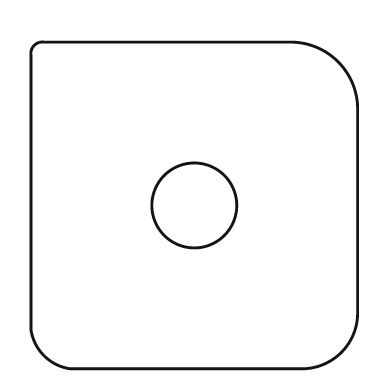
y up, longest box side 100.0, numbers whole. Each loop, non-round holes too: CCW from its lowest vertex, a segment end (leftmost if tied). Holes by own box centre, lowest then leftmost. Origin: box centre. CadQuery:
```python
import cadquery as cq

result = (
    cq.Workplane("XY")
    .moveTo(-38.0, -50.0)
    .lineTo(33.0, -50.0)
    .threePointArc((45.0, -45.0), (50.0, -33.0))
    .lineTo(50.0, 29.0)
    .threePointArc((44.0, 44.0), (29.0, 50.0))
    .lineTo(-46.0, 50.0)
    .threePointArc((-49.0, 49.0), (-50.0, 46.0))
    .lineTo(-50.0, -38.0)
    .threePointArc((-46.0, -46.0), (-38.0, -50.0))
    .close()
    .moveTo(0.0, 0.0)
    .circle(13.0)
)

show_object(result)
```